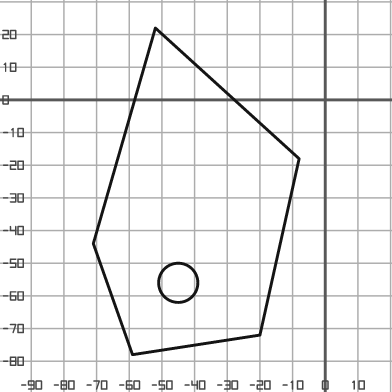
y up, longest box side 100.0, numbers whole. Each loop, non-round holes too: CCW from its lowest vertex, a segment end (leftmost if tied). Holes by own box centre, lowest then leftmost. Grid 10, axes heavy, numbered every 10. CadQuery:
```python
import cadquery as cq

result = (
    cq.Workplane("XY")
    .moveTo(-59.0, -78.0)
    .lineTo(-20.0, -72.0)
    .lineTo(-8.0, -18.0)
    .lineTo(-52.0, 22.0)
    .lineTo(-71.0, -44.0)
    .close()
    .moveTo(-45.0, -56.0)
    .circle(6.0)
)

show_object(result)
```